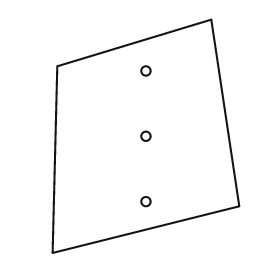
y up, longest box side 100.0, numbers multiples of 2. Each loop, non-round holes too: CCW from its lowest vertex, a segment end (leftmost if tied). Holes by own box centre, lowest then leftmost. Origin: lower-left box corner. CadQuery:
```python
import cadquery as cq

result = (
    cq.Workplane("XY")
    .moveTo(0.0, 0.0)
    .lineTo(80.0, 20.0)
    .lineTo(68.0, 100.0)
    .lineTo(2.0, 80.0)
    .close()
    .moveTo(40.0, 22.0)
    .circle(2.0)
    .moveTo(40.0, 50.0)
    .circle(2.0)
    .moveTo(40.0, 78.0)
    .circle(2.0)
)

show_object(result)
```